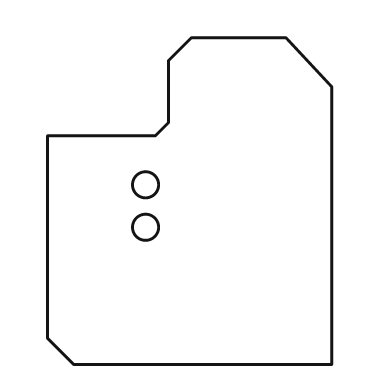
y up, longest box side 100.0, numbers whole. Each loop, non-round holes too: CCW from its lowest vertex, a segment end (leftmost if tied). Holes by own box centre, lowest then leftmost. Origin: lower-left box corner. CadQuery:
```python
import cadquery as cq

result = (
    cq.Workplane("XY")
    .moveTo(8.0, 0.0)
    .lineTo(87.0, 0.0)
    .lineTo(87.0, 85.0)
    .lineTo(73.0, 100.0)
    .lineTo(44.0, 100.0)
    .lineTo(37.0, 93.0)
    .lineTo(37.0, 74.0)
    .lineTo(33.0, 70.0)
    .lineTo(0.0, 70.0)
    .lineTo(0.0, 8.0)
    .close()
    .moveTo(30.0, 42.0)
    .circle(4.0)
    .moveTo(30.0, 55.0)
    .circle(4.0)
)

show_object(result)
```